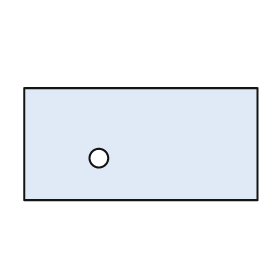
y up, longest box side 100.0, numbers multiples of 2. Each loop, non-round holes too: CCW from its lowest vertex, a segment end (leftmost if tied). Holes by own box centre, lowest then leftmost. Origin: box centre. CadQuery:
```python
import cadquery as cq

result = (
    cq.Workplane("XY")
    .moveTo(-50.0, -24.0)
    .lineTo(50.0, -24.0)
    .lineTo(50.0, 24.0)
    .lineTo(-50.0, 24.0)
    .close()
    .moveTo(-18.0, -6.0)
    .circle(4.0)
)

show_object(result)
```